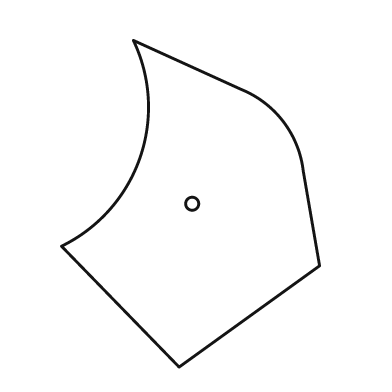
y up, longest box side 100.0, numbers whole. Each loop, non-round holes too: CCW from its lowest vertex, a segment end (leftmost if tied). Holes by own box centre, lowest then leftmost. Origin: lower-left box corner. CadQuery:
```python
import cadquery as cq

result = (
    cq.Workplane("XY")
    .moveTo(36.0, 0.0)
    .lineTo(79.0, 31.0)
    .lineTo(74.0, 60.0)
    .threePointArc((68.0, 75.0), (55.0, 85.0))
    .lineTo(22.0, 100.0)
    .threePointArc((24.0, 64.0), (0.0, 37.0))
    .close()
    .moveTo(40.0, 50.0)
    .circle(2.0)
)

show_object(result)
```